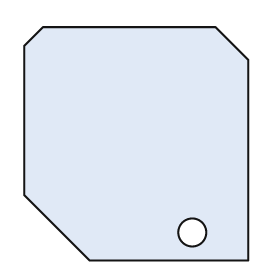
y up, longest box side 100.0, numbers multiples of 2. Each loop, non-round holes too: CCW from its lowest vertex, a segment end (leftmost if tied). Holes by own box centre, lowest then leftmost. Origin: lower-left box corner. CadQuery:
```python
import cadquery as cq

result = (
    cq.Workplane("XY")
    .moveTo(28.0, 0.0)
    .lineTo(96.0, 0.0)
    .lineTo(96.0, 86.0)
    .lineTo(82.0, 100.0)
    .lineTo(8.0, 100.0)
    .lineTo(0.0, 92.0)
    .lineTo(0.0, 28.0)
    .close()
    .moveTo(72.0, 12.0)
    .circle(6.0)
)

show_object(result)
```